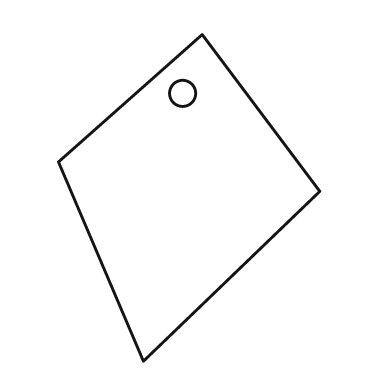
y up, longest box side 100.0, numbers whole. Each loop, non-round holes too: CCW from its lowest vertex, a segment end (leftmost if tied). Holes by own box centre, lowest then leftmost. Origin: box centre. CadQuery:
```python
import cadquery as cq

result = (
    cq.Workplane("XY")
    .moveTo(-14.0, -50.0)
    .lineTo(40.0, 2.0)
    .lineTo(4.0, 50.0)
    .lineTo(-40.0, 11.0)
    .close()
    .moveTo(-2.0, 32.0)
    .circle(4.0)
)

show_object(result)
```